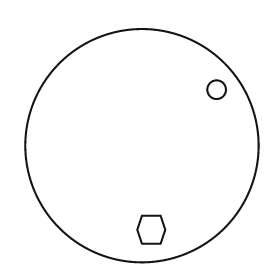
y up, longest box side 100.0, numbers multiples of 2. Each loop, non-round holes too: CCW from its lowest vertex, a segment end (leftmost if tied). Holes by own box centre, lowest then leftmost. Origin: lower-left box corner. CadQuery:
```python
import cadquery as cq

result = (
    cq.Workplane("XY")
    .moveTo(50.0, 50.0)
    .circle(50.0)
    .moveTo(50.0, 8.0)
    .lineTo(58.0, 8.0)
    .lineTo(60.0, 14.0)
    .lineTo(58.0, 20.0)
    .lineTo(50.0, 20.0)
    .lineTo(48.0, 14.0)
    .close()
    .moveTo(82.0, 74.0)
    .circle(4.0)
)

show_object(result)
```